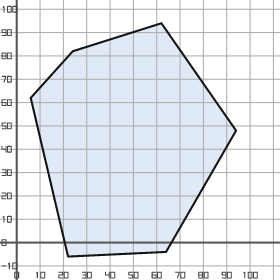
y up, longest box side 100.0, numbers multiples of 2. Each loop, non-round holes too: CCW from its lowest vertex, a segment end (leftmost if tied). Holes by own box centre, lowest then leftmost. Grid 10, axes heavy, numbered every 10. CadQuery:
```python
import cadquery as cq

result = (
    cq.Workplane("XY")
    .moveTo(22.0, -6.0)
    .lineTo(64.0, -4.0)
    .lineTo(94.0, 48.0)
    .lineTo(62.0, 94.0)
    .lineTo(24.0, 82.0)
    .lineTo(6.0, 62.0)
    .close()
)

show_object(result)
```